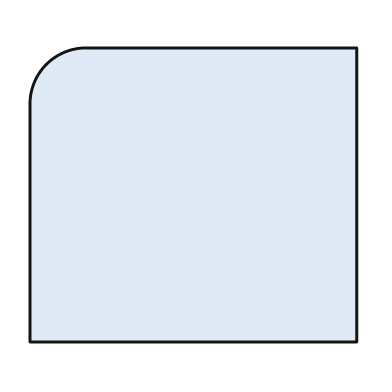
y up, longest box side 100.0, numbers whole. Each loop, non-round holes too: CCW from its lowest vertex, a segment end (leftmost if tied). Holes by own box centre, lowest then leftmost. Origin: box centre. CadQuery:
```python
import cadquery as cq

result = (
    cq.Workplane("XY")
    .moveTo(-50.0, -45.0)
    .lineTo(50.0, -45.0)
    .lineTo(50.0, 45.0)
    .lineTo(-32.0, 45.0)
    .threePointArc((-45.0, 40.0), (-50.0, 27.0))
    .close()
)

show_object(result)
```